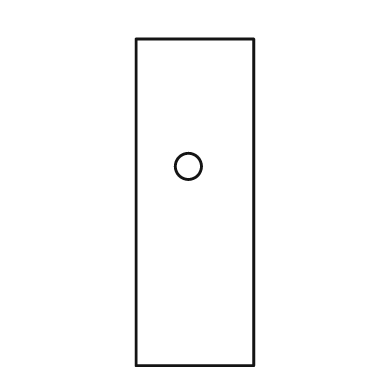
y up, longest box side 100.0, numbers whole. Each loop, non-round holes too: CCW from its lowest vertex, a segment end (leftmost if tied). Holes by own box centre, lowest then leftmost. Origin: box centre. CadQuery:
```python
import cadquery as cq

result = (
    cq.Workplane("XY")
    .moveTo(-18.0, -50.0)
    .lineTo(18.0, -50.0)
    .lineTo(18.0, 50.0)
    .lineTo(-18.0, 50.0)
    .close()
    .moveTo(-2.0, 11.0)
    .circle(4.0)
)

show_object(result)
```